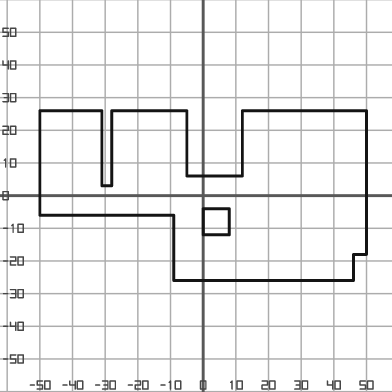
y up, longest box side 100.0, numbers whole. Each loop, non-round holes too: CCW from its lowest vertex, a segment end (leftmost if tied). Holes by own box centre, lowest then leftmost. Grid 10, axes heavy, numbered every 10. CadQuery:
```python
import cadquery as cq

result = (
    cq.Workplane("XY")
    .moveTo(-9.0, -26.0)
    .lineTo(46.0, -26.0)
    .lineTo(46.0, -18.0)
    .lineTo(50.0, -18.0)
    .lineTo(50.0, 26.0)
    .lineTo(12.0, 26.0)
    .lineTo(12.0, 6.0)
    .lineTo(-5.0, 6.0)
    .lineTo(-5.0, 26.0)
    .lineTo(-28.0, 26.0)
    .lineTo(-28.0, 3.0)
    .lineTo(-31.0, 3.0)
    .lineTo(-31.0, 26.0)
    .lineTo(-50.0, 26.0)
    .lineTo(-50.0, -6.0)
    .lineTo(-9.0, -6.0)
    .close()
    .moveTo(0.0, -12.0)
    .lineTo(8.0, -12.0)
    .lineTo(8.0, -4.0)
    .lineTo(0.0, -4.0)
    .close()
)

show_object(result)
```